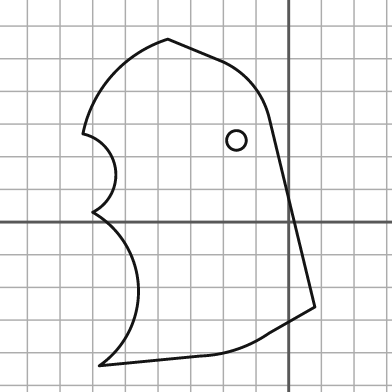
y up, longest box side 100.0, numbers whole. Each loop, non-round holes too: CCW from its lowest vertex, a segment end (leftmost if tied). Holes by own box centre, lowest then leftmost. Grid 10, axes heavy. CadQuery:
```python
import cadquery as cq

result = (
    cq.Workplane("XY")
    .moveTo(-58.0, -44.0)
    .lineTo(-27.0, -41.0)
    .threePointArc((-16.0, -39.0), (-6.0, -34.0))
    .lineTo(8.0, -26.0)
    .lineTo(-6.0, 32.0)
    .threePointArc((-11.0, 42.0), (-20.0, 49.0))
    .lineTo(-37.0, 56.0)
    .threePointArc((-54.0, 45.0), (-63.0, 27.0))
    .threePointArc((-53.0, 16.0), (-60.0, 3.0))
    .threePointArc((-46.0, -20.0), (-58.0, -44.0))
    .close()
    .moveTo(-16.0, 25.0)
    .circle(3.0)
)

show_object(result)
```